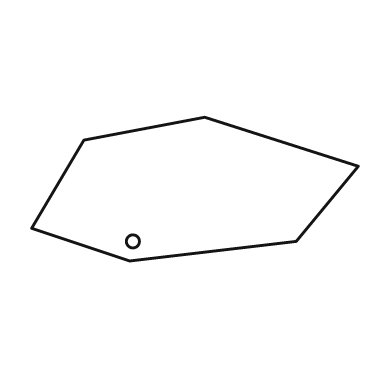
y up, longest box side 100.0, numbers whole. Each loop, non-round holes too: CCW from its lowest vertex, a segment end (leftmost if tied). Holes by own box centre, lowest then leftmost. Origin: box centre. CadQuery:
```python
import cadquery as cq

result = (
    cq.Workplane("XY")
    .moveTo(-20.0, -22.0)
    .lineTo(31.0, -16.0)
    .lineTo(50.0, 7.0)
    .lineTo(3.0, 22.0)
    .lineTo(-34.0, 15.0)
    .lineTo(-50.0, -12.0)
    .close()
    .moveTo(-19.0, -16.0)
    .circle(2.0)
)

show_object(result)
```